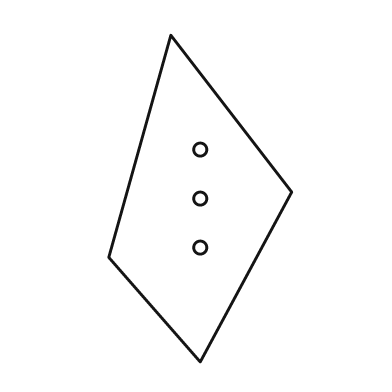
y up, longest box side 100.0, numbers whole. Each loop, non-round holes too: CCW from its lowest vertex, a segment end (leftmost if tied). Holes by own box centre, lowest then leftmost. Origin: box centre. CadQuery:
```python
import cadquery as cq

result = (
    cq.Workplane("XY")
    .moveTo(0.0, -50.0)
    .lineTo(28.0, 2.0)
    .lineTo(-9.0, 50.0)
    .lineTo(-28.0, -18.0)
    .close()
    .moveTo(0.0, -15.0)
    .circle(2.0)
    .moveTo(0.0, 0.0)
    .circle(2.0)
    .moveTo(0.0, 15.0)
    .circle(2.0)
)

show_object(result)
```